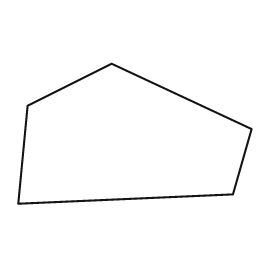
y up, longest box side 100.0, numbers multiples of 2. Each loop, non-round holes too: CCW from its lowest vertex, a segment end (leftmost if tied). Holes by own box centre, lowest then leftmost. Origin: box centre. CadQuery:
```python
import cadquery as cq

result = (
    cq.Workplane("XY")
    .moveTo(-50.0, -30.0)
    .lineTo(42.0, -26.0)
    .lineTo(50.0, 2.0)
    .lineTo(-10.0, 30.0)
    .lineTo(-46.0, 12.0)
    .close()
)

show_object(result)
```